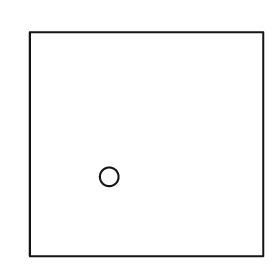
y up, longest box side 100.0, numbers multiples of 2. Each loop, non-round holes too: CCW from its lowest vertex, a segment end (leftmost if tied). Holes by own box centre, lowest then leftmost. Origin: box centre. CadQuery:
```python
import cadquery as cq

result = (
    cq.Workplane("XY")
    .moveTo(-50.0, -48.0)
    .lineTo(50.0, -48.0)
    .lineTo(50.0, 48.0)
    .lineTo(-50.0, 48.0)
    .close()
    .moveTo(-16.0, -14.0)
    .circle(4.0)
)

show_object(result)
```